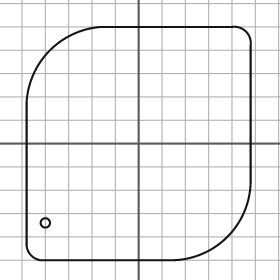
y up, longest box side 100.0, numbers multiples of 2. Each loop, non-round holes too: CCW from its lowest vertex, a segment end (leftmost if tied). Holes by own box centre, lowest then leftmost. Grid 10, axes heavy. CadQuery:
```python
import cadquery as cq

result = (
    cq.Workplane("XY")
    .moveTo(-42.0, -50.0)
    .lineTo(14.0, -50.0)
    .threePointArc((38.0, -40.0), (48.0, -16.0))
    .lineTo(48.0, 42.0)
    .threePointArc((46.0, 48.0), (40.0, 50.0))
    .lineTo(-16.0, 50.0)
    .threePointArc((-38.0, 40.0), (-48.0, 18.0))
    .lineTo(-48.0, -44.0)
    .threePointArc((-46.0, -48.0), (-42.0, -50.0))
    .close()
    .moveTo(-40.0, -34.0)
    .circle(2.0)
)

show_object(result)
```